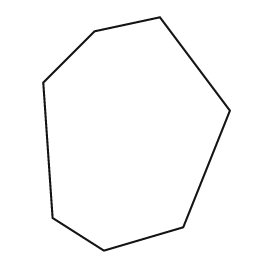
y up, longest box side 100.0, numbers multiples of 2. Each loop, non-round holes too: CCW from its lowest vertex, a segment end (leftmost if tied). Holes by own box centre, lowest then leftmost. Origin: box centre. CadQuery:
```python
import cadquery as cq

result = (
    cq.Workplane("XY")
    .moveTo(-14.0, -50.0)
    .lineTo(20.0, -40.0)
    .lineTo(40.0, 10.0)
    .lineTo(10.0, 50.0)
    .lineTo(-18.0, 44.0)
    .lineTo(-40.0, 22.0)
    .lineTo(-36.0, -36.0)
    .close()
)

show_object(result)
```